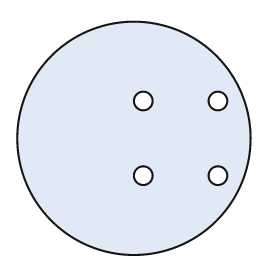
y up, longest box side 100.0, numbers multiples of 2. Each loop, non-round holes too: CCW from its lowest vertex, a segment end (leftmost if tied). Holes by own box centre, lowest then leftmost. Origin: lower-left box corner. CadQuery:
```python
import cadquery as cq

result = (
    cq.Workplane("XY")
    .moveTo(50.0, 50.0)
    .circle(50.0)
    .moveTo(54.0, 34.0)
    .circle(4.0)
    .moveTo(86.0, 34.0)
    .circle(4.0)
    .moveTo(54.0, 66.0)
    .circle(4.0)
    .moveTo(86.0, 66.0)
    .circle(4.0)
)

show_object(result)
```